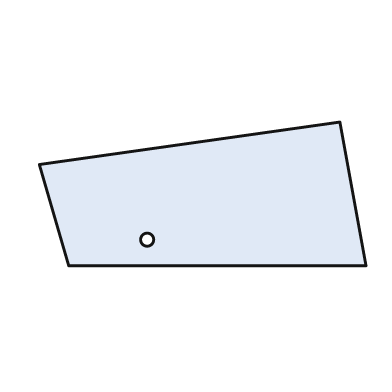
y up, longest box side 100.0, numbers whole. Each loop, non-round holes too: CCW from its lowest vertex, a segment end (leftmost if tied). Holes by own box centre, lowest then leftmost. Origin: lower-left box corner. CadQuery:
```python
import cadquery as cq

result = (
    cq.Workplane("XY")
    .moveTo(9.0, 0.0)
    .lineTo(100.0, 0.0)
    .lineTo(92.0, 44.0)
    .lineTo(0.0, 31.0)
    .close()
    .moveTo(33.0, 8.0)
    .circle(2.0)
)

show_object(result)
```